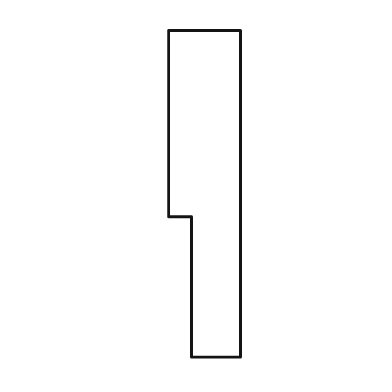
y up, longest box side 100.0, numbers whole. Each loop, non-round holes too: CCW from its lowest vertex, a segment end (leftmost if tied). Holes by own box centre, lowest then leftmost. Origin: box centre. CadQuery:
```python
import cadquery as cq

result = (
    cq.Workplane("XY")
    .moveTo(-4.0, -50.0)
    .lineTo(11.0, -50.0)
    .lineTo(11.0, 50.0)
    .lineTo(-11.0, 50.0)
    .lineTo(-11.0, -7.0)
    .lineTo(-4.0, -7.0)
    .close()
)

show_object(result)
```